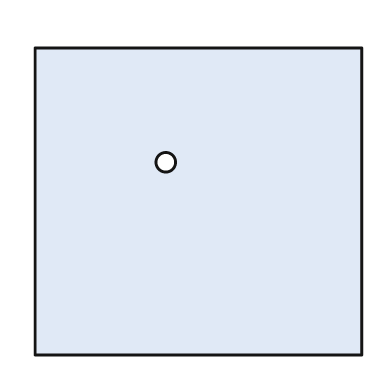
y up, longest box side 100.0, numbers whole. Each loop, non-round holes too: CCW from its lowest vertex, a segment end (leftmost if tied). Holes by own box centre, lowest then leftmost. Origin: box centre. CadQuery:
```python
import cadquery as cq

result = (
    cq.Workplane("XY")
    .moveTo(-50.0, -47.0)
    .lineTo(50.0, -47.0)
    .lineTo(50.0, 47.0)
    .lineTo(-50.0, 47.0)
    .close()
    .moveTo(-10.0, 12.0)
    .circle(3.0)
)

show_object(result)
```